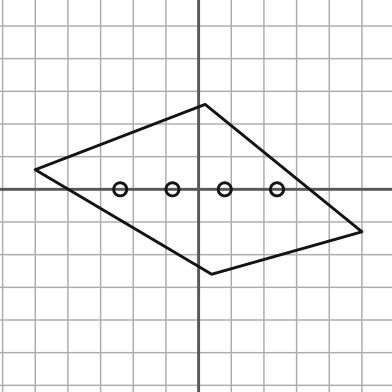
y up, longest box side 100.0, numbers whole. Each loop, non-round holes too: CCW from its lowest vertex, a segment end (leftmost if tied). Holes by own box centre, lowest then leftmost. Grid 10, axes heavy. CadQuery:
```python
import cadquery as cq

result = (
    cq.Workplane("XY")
    .moveTo(4.0, -26.0)
    .lineTo(50.0, -13.0)
    .lineTo(2.0, 26.0)
    .lineTo(-50.0, 6.0)
    .close()
    .moveTo(-24.0, 0.0)
    .circle(2.0)
    .moveTo(-8.0, 0.0)
    .circle(2.0)
    .moveTo(8.0, 0.0)
    .circle(2.0)
    .moveTo(24.0, 0.0)
    .circle(2.0)
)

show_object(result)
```